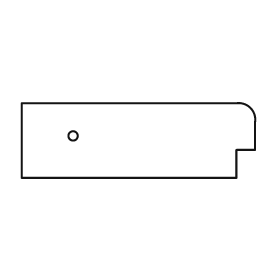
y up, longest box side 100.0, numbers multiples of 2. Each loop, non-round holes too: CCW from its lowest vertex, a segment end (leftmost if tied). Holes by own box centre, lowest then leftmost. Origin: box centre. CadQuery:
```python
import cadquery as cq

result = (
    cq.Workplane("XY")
    .moveTo(-50.0, -16.0)
    .lineTo(42.0, -16.0)
    .lineTo(42.0, -4.0)
    .lineTo(50.0, -4.0)
    .lineTo(50.0, 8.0)
    .threePointArc((48.0, 14.0), (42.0, 16.0))
    .lineTo(-50.0, 16.0)
    .close()
    .moveTo(-28.0, 2.0)
    .circle(2.0)
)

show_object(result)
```